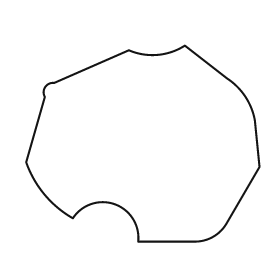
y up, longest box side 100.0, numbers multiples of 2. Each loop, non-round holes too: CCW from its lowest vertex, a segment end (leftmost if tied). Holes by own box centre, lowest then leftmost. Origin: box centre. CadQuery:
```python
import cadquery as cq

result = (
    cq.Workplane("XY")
    .moveTo(-2.0, -42.0)
    .lineTo(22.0, -42.0)
    .threePointArc((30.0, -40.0), (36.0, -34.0))
    .lineTo(50.0, -10.0)
    .lineTo(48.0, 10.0)
    .threePointArc((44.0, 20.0), (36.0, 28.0))
    .lineTo(18.0, 42.0)
    .threePointArc((6.0, 38.0), (-6.0, 40.0))
    .lineTo(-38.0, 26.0)
    .threePointArc((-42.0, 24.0), (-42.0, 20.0))
    .lineTo(-50.0, -8.0)
    .threePointArc((-42.0, -22.0), (-30.0, -32.0))
    .threePointArc((-12.0, -26.0), (-2.0, -42.0))
    .close()
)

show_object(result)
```